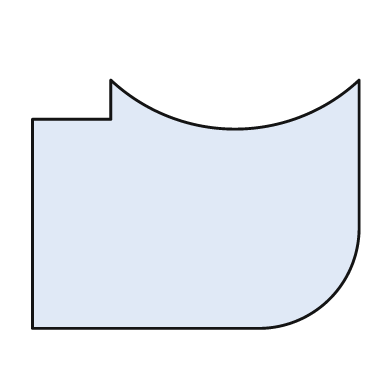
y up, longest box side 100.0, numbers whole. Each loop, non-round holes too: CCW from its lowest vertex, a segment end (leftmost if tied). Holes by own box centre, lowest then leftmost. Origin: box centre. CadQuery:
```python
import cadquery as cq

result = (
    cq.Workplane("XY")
    .moveTo(-50.0, -38.0)
    .lineTo(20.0, -38.0)
    .threePointArc((41.0, -29.0), (50.0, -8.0))
    .lineTo(50.0, 38.0)
    .threePointArc((12.0, 23.0), (-26.0, 38.0))
    .lineTo(-26.0, 26.0)
    .lineTo(-50.0, 26.0)
    .close()
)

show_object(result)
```